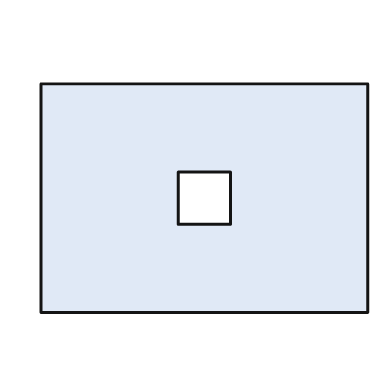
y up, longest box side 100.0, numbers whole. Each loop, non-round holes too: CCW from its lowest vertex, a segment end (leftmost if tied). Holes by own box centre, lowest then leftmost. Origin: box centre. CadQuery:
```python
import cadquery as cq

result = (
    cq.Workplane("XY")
    .moveTo(-50.0, -35.0)
    .lineTo(50.0, -35.0)
    .lineTo(50.0, 35.0)
    .lineTo(-50.0, 35.0)
    .close()
    .moveTo(-8.0, -8.0)
    .lineTo(8.0, -8.0)
    .lineTo(8.0, 8.0)
    .lineTo(-8.0, 8.0)
    .close()
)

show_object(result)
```